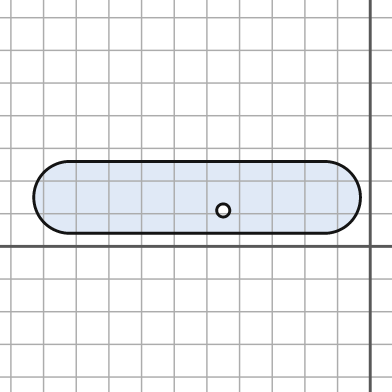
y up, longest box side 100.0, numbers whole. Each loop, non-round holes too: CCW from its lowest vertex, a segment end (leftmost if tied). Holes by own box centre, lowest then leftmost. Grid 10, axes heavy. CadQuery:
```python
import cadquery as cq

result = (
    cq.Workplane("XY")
    .moveTo(-92.0, 4.0)
    .lineTo(-14.0, 4.0)
    .threePointArc((-3.0, 15.0), (-14.0, 26.0))
    .lineTo(-92.0, 26.0)
    .threePointArc((-103.0, 15.0), (-92.0, 4.0))
    .close()
    .moveTo(-45.0, 11.0)
    .circle(2.0)
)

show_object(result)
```